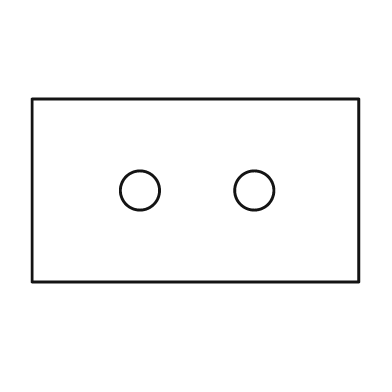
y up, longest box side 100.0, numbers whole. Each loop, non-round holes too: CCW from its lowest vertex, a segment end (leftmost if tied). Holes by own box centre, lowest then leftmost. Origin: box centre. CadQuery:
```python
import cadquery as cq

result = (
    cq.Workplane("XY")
    .moveTo(-50.0, -28.0)
    .lineTo(50.0, -28.0)
    .lineTo(50.0, 28.0)
    .lineTo(-50.0, 28.0)
    .close()
    .moveTo(-17.0, 0.0)
    .circle(6.0)
    .moveTo(18.0, 0.0)
    .circle(6.0)
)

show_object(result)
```